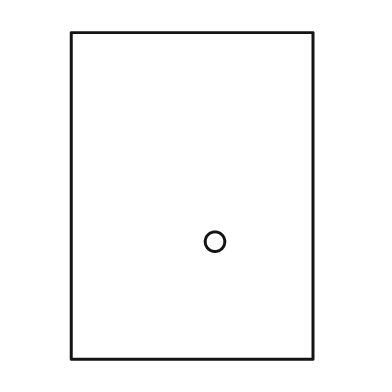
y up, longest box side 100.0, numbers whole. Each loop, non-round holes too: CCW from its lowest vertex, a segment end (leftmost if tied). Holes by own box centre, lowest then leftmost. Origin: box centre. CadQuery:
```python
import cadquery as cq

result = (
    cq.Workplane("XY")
    .moveTo(-37.0, -50.0)
    .lineTo(37.0, -50.0)
    .lineTo(37.0, 50.0)
    .lineTo(-37.0, 50.0)
    .close()
    .moveTo(7.0, -14.0)
    .circle(3.0)
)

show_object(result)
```